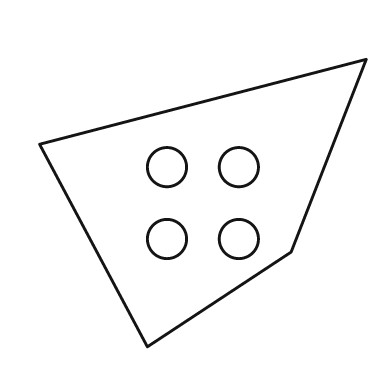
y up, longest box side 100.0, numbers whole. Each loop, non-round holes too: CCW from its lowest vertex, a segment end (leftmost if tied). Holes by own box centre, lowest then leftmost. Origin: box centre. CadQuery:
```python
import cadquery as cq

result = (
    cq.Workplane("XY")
    .moveTo(-17.0, -44.0)
    .lineTo(27.0, -15.0)
    .lineTo(50.0, 44.0)
    .lineTo(-50.0, 18.0)
    .close()
    .moveTo(-11.0, -11.0)
    .circle(6.0)
    .moveTo(11.0, -11.0)
    .circle(6.0)
    .moveTo(-11.0, 11.0)
    .circle(6.0)
    .moveTo(11.0, 11.0)
    .circle(6.0)
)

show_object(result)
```